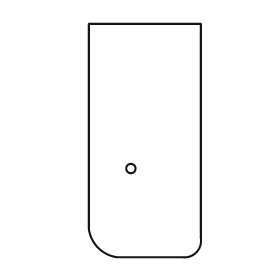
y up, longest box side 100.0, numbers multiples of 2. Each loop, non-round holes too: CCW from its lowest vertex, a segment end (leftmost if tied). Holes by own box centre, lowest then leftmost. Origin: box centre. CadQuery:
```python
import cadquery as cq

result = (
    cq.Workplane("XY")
    .moveTo(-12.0, -50.0)
    .lineTo(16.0, -50.0)
    .threePointArc((22.0, -48.0), (24.0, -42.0))
    .lineTo(24.0, 50.0)
    .lineTo(-24.0, 50.0)
    .lineTo(-24.0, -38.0)
    .threePointArc((-20.0, -46.0), (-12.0, -50.0))
    .close()
    .moveTo(-6.0, -12.0)
    .circle(2.0)
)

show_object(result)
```